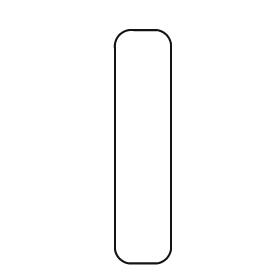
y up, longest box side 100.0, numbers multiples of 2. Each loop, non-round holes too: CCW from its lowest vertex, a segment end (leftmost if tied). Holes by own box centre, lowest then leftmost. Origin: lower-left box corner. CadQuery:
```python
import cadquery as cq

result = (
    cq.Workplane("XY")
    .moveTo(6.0, 0.0)
    .lineTo(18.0, 0.0)
    .threePointArc((22.0, 2.0), (24.0, 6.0))
    .lineTo(24.0, 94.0)
    .threePointArc((22.0, 98.0), (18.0, 100.0))
    .lineTo(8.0, 100.0)
    .threePointArc((2.0, 98.0), (0.0, 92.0))
    .lineTo(0.0, 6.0)
    .threePointArc((2.0, 2.0), (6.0, 0.0))
    .close()
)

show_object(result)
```